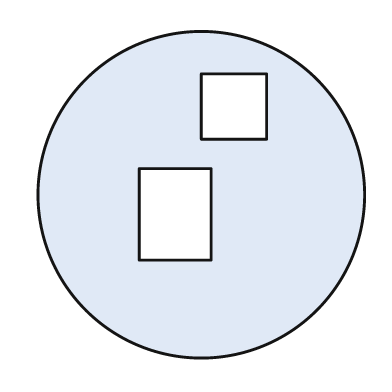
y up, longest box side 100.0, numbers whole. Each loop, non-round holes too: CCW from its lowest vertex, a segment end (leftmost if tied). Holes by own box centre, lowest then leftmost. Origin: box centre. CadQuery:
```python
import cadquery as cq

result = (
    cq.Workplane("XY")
    .moveTo(0.0, 0.0)
    .circle(50.0)
    .moveTo(-19.0, -20.0)
    .lineTo(3.0, -20.0)
    .lineTo(3.0, 8.0)
    .lineTo(-19.0, 8.0)
    .close()
    .moveTo(0.0, 17.0)
    .lineTo(20.0, 17.0)
    .lineTo(20.0, 37.0)
    .lineTo(0.0, 37.0)
    .close()
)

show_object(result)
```